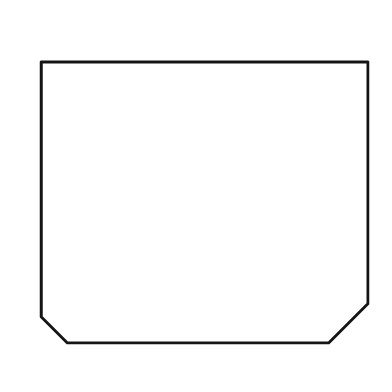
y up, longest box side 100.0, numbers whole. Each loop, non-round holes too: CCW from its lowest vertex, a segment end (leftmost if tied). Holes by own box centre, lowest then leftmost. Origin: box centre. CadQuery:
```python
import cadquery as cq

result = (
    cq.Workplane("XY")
    .moveTo(-42.0, -43.0)
    .lineTo(38.0, -43.0)
    .lineTo(50.0, -31.0)
    .lineTo(50.0, 43.0)
    .lineTo(-50.0, 43.0)
    .lineTo(-50.0, -35.0)
    .close()
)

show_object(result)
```